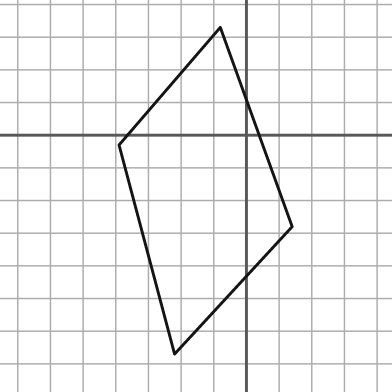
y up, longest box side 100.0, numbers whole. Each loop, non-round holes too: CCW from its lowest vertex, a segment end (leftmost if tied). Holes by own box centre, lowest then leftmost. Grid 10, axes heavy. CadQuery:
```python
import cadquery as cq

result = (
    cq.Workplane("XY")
    .moveTo(-22.0, -67.0)
    .lineTo(14.0, -28.0)
    .lineTo(-8.0, 33.0)
    .lineTo(-39.0, -3.0)
    .close()
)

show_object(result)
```